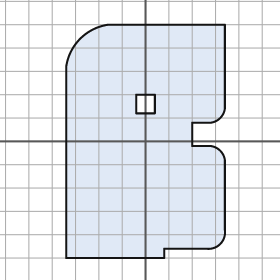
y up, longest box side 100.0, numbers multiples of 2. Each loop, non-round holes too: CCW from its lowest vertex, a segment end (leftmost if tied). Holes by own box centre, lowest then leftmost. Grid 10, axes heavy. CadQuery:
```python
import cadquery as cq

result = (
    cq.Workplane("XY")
    .moveTo(-34.0, -50.0)
    .lineTo(8.0, -50.0)
    .lineTo(8.0, -46.0)
    .lineTo(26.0, -46.0)
    .threePointArc((32.0, -44.0), (34.0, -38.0))
    .lineTo(34.0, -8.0)
    .threePointArc((32.0, -4.0), (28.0, -2.0))
    .lineTo(20.0, -2.0)
    .lineTo(20.0, 8.0)
    .lineTo(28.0, 8.0)
    .threePointArc((32.0, 10.0), (34.0, 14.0))
    .lineTo(34.0, 50.0)
    .lineTo(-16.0, 50.0)
    .threePointArc((-28.0, 44.0), (-34.0, 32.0))
    .close()
    .moveTo(-4.0, 12.0)
    .lineTo(4.0, 12.0)
    .lineTo(4.0, 20.0)
    .lineTo(-4.0, 20.0)
    .close()
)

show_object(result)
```